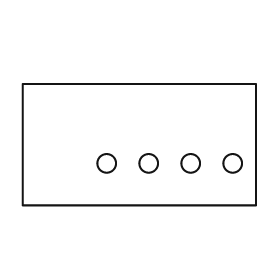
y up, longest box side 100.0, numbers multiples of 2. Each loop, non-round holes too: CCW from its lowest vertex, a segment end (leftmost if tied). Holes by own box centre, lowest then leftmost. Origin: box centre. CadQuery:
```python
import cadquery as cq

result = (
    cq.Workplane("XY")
    .moveTo(-50.0, -26.0)
    .lineTo(50.0, -26.0)
    .lineTo(50.0, 26.0)
    .lineTo(-50.0, 26.0)
    .close()
    .moveTo(-14.0, -8.0)
    .circle(4.0)
    .moveTo(4.0, -8.0)
    .circle(4.0)
    .moveTo(22.0, -8.0)
    .circle(4.0)
    .moveTo(40.0, -8.0)
    .circle(4.0)
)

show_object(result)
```